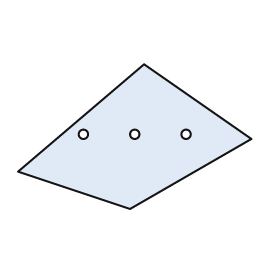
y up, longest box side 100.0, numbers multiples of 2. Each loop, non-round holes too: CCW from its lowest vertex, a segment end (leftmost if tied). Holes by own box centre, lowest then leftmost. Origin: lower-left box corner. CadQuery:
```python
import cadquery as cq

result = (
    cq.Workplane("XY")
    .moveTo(48.0, 0.0)
    .lineTo(100.0, 30.0)
    .lineTo(54.0, 62.0)
    .lineTo(0.0, 16.0)
    .close()
    .moveTo(28.0, 32.0)
    .circle(2.0)
    .moveTo(50.0, 32.0)
    .circle(2.0)
    .moveTo(72.0, 32.0)
    .circle(2.0)
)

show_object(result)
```